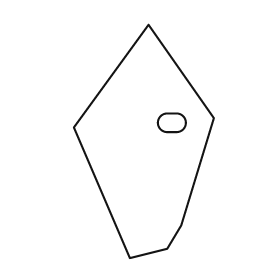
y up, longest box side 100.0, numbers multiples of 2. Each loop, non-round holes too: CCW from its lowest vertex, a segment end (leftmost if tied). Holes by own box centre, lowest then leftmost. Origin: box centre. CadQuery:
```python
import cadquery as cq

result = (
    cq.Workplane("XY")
    .moveTo(-6.0, -50.0)
    .lineTo(10.0, -46.0)
    .lineTo(16.0, -36.0)
    .lineTo(30.0, 10.0)
    .lineTo(2.0, 50.0)
    .lineTo(-30.0, 6.0)
    .close()
    .moveTo(10.0, 4.0)
    .lineTo(14.0, 4.0)
    .threePointArc((18.0, 8.0), (14.0, 12.0))
    .lineTo(10.0, 12.0)
    .threePointArc((6.0, 8.0), (10.0, 4.0))
    .close()
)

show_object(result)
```